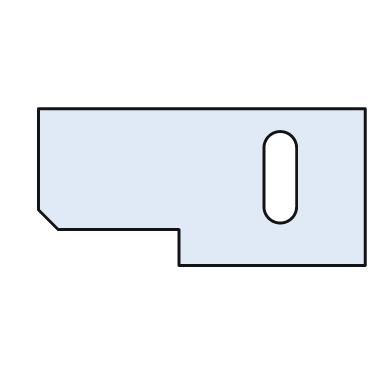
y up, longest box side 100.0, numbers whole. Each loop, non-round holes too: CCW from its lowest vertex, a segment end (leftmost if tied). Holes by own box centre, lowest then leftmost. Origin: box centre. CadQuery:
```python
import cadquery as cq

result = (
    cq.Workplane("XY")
    .moveTo(-7.0, -24.0)
    .lineTo(50.0, -24.0)
    .lineTo(50.0, 24.0)
    .lineTo(-50.0, 24.0)
    .lineTo(-50.0, -7.0)
    .lineTo(-44.0, -13.0)
    .lineTo(-7.0, -13.0)
    .close()
    .moveTo(19.0, -6.0)
    .threePointArc((24.0, -11.0), (29.0, -6.0))
    .lineTo(29.0, 12.0)
    .threePointArc((24.0, 17.0), (19.0, 12.0))
    .close()
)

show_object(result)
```